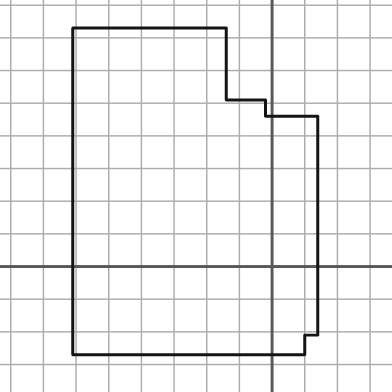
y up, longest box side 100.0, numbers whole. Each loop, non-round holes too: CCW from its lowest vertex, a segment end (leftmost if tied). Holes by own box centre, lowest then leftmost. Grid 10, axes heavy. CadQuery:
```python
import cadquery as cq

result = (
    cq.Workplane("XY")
    .moveTo(-61.0, -27.0)
    .lineTo(10.0, -27.0)
    .lineTo(10.0, -21.0)
    .lineTo(14.0, -21.0)
    .lineTo(14.0, 46.0)
    .lineTo(-2.0, 46.0)
    .lineTo(-2.0, 51.0)
    .lineTo(-14.0, 51.0)
    .lineTo(-14.0, 73.0)
    .lineTo(-61.0, 73.0)
    .close()
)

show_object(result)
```